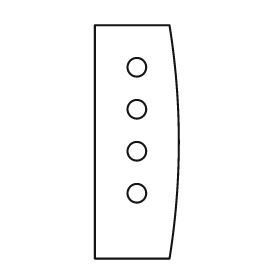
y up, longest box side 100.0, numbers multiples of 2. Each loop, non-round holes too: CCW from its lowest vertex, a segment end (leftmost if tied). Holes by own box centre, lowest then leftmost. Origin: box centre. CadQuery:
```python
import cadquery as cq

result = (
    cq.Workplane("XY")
    .moveTo(-18.0, -50.0)
    .lineTo(14.0, -50.0)
    .threePointArc((18.0, 0.0), (14.0, 50.0))
    .lineTo(-18.0, 50.0)
    .close()
    .moveTo(0.0, -22.0)
    .circle(4.0)
    .moveTo(0.0, -4.0)
    .circle(4.0)
    .moveTo(0.0, 14.0)
    .circle(4.0)
    .moveTo(0.0, 32.0)
    .circle(4.0)
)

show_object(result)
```